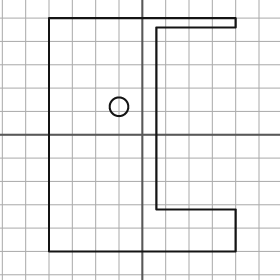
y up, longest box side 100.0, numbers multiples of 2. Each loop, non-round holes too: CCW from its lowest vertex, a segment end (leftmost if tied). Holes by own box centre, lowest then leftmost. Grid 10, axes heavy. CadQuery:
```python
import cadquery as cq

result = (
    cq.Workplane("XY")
    .moveTo(-40.0, -50.0)
    .lineTo(40.0, -50.0)
    .lineTo(40.0, -32.0)
    .lineTo(6.0, -32.0)
    .lineTo(6.0, 46.0)
    .lineTo(40.0, 46.0)
    .lineTo(40.0, 50.0)
    .lineTo(-40.0, 50.0)
    .close()
    .moveTo(-10.0, 12.0)
    .circle(4.0)
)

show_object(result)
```